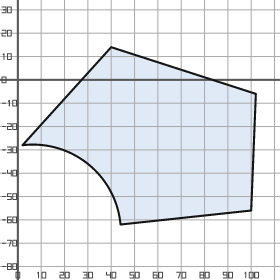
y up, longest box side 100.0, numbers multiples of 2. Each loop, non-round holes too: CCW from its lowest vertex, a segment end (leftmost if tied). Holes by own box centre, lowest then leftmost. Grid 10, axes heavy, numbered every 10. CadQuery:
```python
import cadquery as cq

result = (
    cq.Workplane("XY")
    .moveTo(44.0, -62.0)
    .lineTo(100.0, -56.0)
    .lineTo(102.0, -6.0)
    .lineTo(40.0, 14.0)
    .lineTo(2.0, -28.0)
    .threePointArc((30.0, -36.0), (44.0, -62.0))
    .close()
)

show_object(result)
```